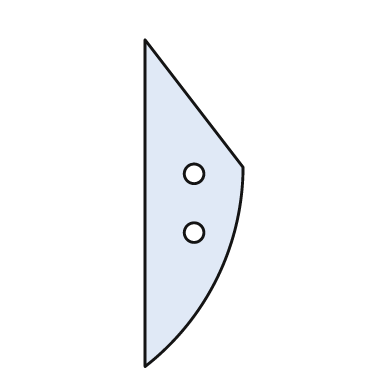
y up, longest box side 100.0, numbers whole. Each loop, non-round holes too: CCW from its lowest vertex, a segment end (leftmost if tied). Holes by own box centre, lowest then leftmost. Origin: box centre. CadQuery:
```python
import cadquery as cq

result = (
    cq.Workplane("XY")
    .moveTo(-15.0, -50.0)
    .threePointArc((7.0, -23.0), (15.0, 11.0))
    .lineTo(-15.0, 50.0)
    .close()
    .moveTo(0.0, -9.0)
    .circle(3.0)
    .moveTo(0.0, 9.0)
    .circle(3.0)
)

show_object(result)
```